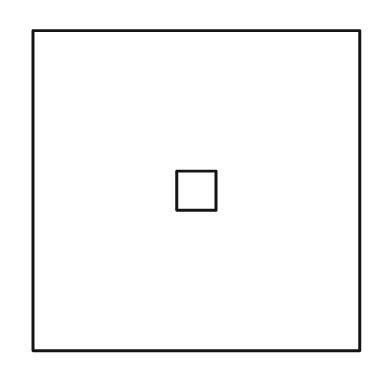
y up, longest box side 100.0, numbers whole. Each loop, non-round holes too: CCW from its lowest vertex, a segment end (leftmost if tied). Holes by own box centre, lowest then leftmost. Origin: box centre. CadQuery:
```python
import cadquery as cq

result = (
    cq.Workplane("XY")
    .moveTo(-50.0, -49.0)
    .lineTo(50.0, -49.0)
    .lineTo(50.0, 49.0)
    .lineTo(-50.0, 49.0)
    .close()
    .moveTo(-6.0, -6.0)
    .lineTo(6.0, -6.0)
    .lineTo(6.0, 6.0)
    .lineTo(-6.0, 6.0)
    .close()
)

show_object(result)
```